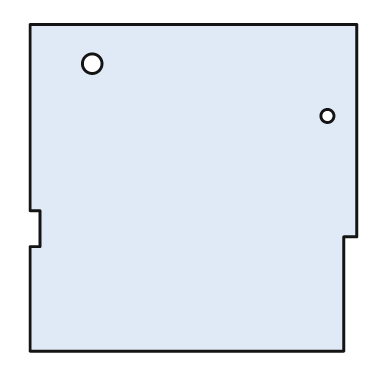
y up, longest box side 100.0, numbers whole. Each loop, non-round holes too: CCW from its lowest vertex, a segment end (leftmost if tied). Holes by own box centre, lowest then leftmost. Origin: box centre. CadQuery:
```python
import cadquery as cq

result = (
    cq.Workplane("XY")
    .moveTo(-50.0, -50.0)
    .lineTo(46.0, -50.0)
    .lineTo(46.0, -15.0)
    .lineTo(50.0, -15.0)
    .lineTo(50.0, 50.0)
    .lineTo(-50.0, 50.0)
    .lineTo(-50.0, -7.0)
    .lineTo(-47.0, -7.0)
    .lineTo(-47.0, -18.0)
    .lineTo(-50.0, -18.0)
    .close()
    .moveTo(41.0, 22.0)
    .circle(2.0)
    .moveTo(-31.0, 38.0)
    .circle(3.0)
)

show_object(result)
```